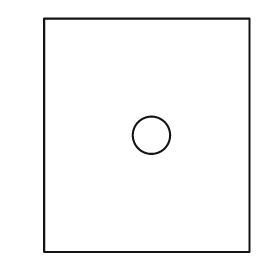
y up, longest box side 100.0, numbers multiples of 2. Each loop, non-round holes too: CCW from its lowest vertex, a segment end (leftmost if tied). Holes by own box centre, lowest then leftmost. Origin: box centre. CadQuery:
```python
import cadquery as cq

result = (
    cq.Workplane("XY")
    .moveTo(-44.0, -50.0)
    .lineTo(44.0, -50.0)
    .lineTo(44.0, 50.0)
    .lineTo(-44.0, 50.0)
    .close()
    .moveTo(2.0, 0.0)
    .circle(8.0)
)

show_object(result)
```